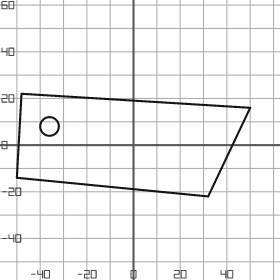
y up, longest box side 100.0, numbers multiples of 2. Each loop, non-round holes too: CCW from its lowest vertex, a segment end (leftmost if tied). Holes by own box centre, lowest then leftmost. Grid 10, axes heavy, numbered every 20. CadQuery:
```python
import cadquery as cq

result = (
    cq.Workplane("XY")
    .moveTo(32.0, -22.0)
    .lineTo(50.0, 16.0)
    .lineTo(-48.0, 22.0)
    .lineTo(-50.0, -14.0)
    .close()
    .moveTo(-36.0, 8.0)
    .circle(4.0)
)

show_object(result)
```